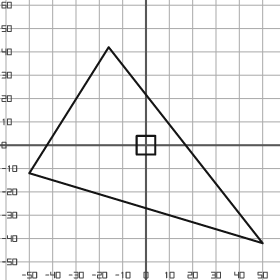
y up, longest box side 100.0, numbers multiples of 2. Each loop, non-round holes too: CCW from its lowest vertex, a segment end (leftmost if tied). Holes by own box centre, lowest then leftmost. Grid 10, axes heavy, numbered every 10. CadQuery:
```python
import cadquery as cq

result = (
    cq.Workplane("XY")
    .moveTo(50.0, -42.0)
    .lineTo(-16.0, 42.0)
    .lineTo(-50.0, -12.0)
    .close()
    .moveTo(-4.0, -4.0)
    .lineTo(4.0, -4.0)
    .lineTo(4.0, 4.0)
    .lineTo(-4.0, 4.0)
    .close()
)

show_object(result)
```